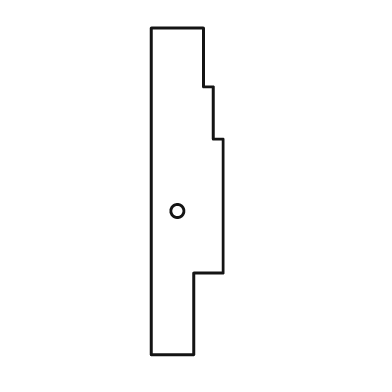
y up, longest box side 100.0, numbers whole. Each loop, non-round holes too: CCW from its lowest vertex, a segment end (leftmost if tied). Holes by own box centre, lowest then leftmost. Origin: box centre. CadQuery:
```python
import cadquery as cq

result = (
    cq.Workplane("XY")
    .moveTo(-11.0, -50.0)
    .lineTo(2.0, -50.0)
    .lineTo(2.0, -25.0)
    .lineTo(11.0, -25.0)
    .lineTo(11.0, 16.0)
    .lineTo(8.0, 16.0)
    .lineTo(8.0, 32.0)
    .lineTo(5.0, 32.0)
    .lineTo(5.0, 50.0)
    .lineTo(-11.0, 50.0)
    .close()
    .moveTo(-3.0, -6.0)
    .circle(2.0)
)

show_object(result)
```